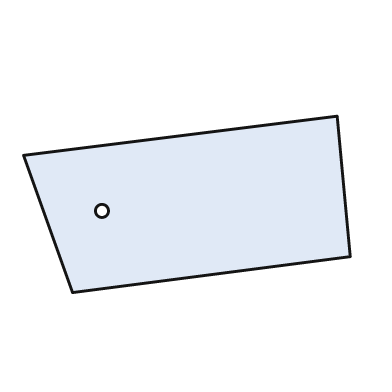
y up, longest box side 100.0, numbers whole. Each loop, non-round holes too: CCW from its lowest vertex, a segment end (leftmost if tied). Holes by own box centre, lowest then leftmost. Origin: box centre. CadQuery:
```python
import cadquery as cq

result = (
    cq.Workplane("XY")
    .moveTo(-35.0, -27.0)
    .lineTo(50.0, -16.0)
    .lineTo(46.0, 27.0)
    .lineTo(-50.0, 15.0)
    .close()
    .moveTo(-26.0, -2.0)
    .circle(2.0)
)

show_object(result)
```